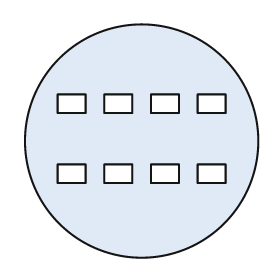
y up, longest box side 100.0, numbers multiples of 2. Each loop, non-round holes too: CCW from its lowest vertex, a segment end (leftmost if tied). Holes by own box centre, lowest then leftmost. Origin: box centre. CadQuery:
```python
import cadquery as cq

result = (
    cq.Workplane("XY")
    .moveTo(0.0, 0.0)
    .circle(50.0)
    .moveTo(-36.0, -18.0)
    .lineTo(-24.0, -18.0)
    .lineTo(-24.0, -10.0)
    .lineTo(-36.0, -10.0)
    .close()
    .moveTo(-16.0, -18.0)
    .lineTo(-4.0, -18.0)
    .lineTo(-4.0, -10.0)
    .lineTo(-16.0, -10.0)
    .close()
    .moveTo(4.0, -18.0)
    .lineTo(16.0, -18.0)
    .lineTo(16.0, -10.0)
    .lineTo(4.0, -10.0)
    .close()
    .moveTo(24.0, -18.0)
    .lineTo(36.0, -18.0)
    .lineTo(36.0, -10.0)
    .lineTo(24.0, -10.0)
    .close()
    .moveTo(-36.0, 12.0)
    .lineTo(-24.0, 12.0)
    .lineTo(-24.0, 20.0)
    .lineTo(-36.0, 20.0)
    .close()
    .moveTo(-16.0, 12.0)
    .lineTo(-4.0, 12.0)
    .lineTo(-4.0, 20.0)
    .lineTo(-16.0, 20.0)
    .close()
    .moveTo(4.0, 12.0)
    .lineTo(16.0, 12.0)
    .lineTo(16.0, 20.0)
    .lineTo(4.0, 20.0)
    .close()
    .moveTo(24.0, 12.0)
    .lineTo(36.0, 12.0)
    .lineTo(36.0, 20.0)
    .lineTo(24.0, 20.0)
    .close()
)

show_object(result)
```